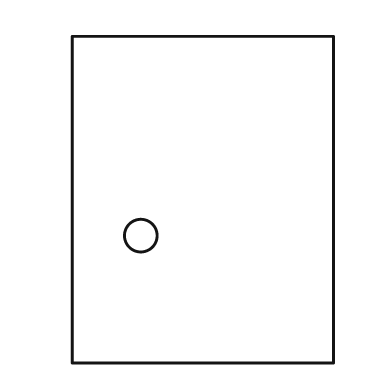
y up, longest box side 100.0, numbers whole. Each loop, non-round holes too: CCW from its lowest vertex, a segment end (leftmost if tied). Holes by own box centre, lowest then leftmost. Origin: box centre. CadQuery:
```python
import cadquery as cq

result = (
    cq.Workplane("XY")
    .moveTo(-40.0, -50.0)
    .lineTo(40.0, -50.0)
    .lineTo(40.0, 50.0)
    .lineTo(-40.0, 50.0)
    .close()
    .moveTo(-19.0, -11.0)
    .circle(5.0)
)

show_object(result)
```